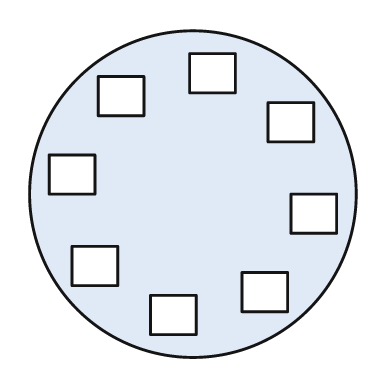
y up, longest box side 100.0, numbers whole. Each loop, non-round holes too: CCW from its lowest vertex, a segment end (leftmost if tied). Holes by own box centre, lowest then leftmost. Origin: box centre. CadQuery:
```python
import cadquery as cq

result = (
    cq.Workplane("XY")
    .moveTo(0.0, 0.0)
    .circle(50.0)
    .moveTo(-13.0, -43.0)
    .lineTo(1.0, -43.0)
    .lineTo(1.0, -31.0)
    .lineTo(-13.0, -31.0)
    .close()
    .moveTo(15.0, -36.0)
    .lineTo(29.0, -36.0)
    .lineTo(29.0, -24.0)
    .lineTo(15.0, -24.0)
    .close()
    .moveTo(-37.0, -28.0)
    .lineTo(-23.0, -28.0)
    .lineTo(-23.0, -16.0)
    .lineTo(-37.0, -16.0)
    .close()
    .moveTo(30.0, -12.0)
    .lineTo(44.0, -12.0)
    .lineTo(44.0, 0.0)
    .lineTo(30.0, 0.0)
    .close()
    .moveTo(-44.0, 0.0)
    .lineTo(-30.0, 0.0)
    .lineTo(-30.0, 12.0)
    .lineTo(-44.0, 12.0)
    .close()
    .moveTo(23.0, 16.0)
    .lineTo(37.0, 16.0)
    .lineTo(37.0, 28.0)
    .lineTo(23.0, 28.0)
    .close()
    .moveTo(-29.0, 24.0)
    .lineTo(-15.0, 24.0)
    .lineTo(-15.0, 36.0)
    .lineTo(-29.0, 36.0)
    .close()
    .moveTo(-1.0, 31.0)
    .lineTo(13.0, 31.0)
    .lineTo(13.0, 43.0)
    .lineTo(-1.0, 43.0)
    .close()
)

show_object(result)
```